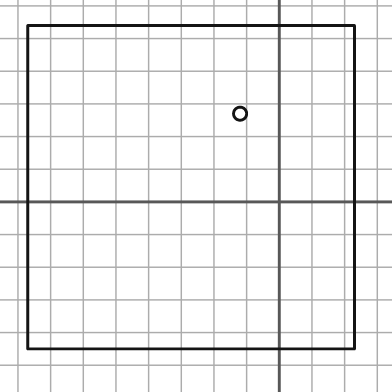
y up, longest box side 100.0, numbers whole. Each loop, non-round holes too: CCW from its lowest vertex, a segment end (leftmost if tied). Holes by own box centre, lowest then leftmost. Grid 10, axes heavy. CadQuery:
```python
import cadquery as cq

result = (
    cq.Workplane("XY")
    .moveTo(-77.0, -45.0)
    .lineTo(23.0, -45.0)
    .lineTo(23.0, 54.0)
    .lineTo(-77.0, 54.0)
    .close()
    .moveTo(-12.0, 27.0)
    .circle(2.0)
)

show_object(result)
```